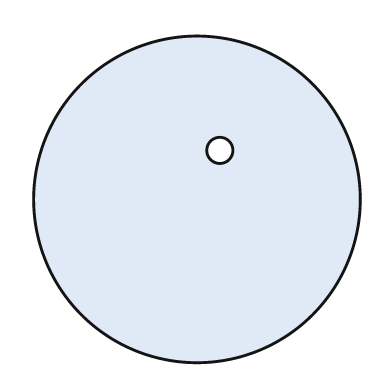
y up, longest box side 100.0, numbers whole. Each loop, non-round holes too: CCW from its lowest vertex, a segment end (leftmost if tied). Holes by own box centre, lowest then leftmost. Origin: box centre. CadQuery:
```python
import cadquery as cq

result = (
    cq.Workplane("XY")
    .moveTo(0.0, 0.0)
    .circle(50.0)
    .moveTo(7.0, 15.0)
    .circle(4.0)
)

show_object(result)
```